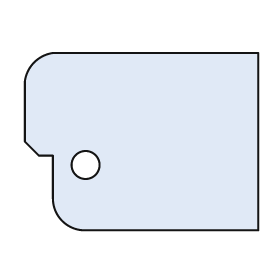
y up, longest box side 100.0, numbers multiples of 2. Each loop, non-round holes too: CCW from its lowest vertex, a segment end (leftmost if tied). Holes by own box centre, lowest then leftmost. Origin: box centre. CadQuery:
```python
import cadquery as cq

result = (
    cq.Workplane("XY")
    .moveTo(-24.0, -38.0)
    .lineTo(50.0, -38.0)
    .lineTo(50.0, 38.0)
    .lineTo(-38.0, 38.0)
    .threePointArc((-46.0, 34.0), (-50.0, 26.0))
    .lineTo(-50.0, 0.0)
    .lineTo(-44.0, -6.0)
    .lineTo(-38.0, -6.0)
    .lineTo(-38.0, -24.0)
    .threePointArc((-34.0, -34.0), (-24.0, -38.0))
    .close()
    .moveTo(-24.0, -10.0)
    .circle(6.0)
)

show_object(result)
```